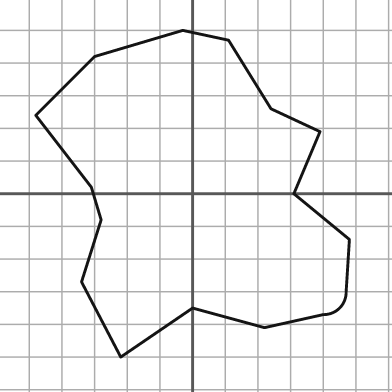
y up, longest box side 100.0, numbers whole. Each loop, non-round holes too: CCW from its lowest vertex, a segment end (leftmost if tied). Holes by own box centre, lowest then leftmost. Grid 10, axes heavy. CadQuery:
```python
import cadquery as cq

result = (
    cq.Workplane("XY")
    .moveTo(-22.0, -50.0)
    .lineTo(0.0, -35.0)
    .lineTo(22.0, -41.0)
    .lineTo(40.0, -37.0)
    .threePointArc((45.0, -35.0), (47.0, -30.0))
    .lineTo(48.0, -14.0)
    .lineTo(31.0, 0.0)
    .lineTo(39.0, 19.0)
    .lineTo(24.0, 26.0)
    .lineTo(11.0, 47.0)
    .lineTo(-3.0, 50.0)
    .lineTo(-30.0, 42.0)
    .lineTo(-48.0, 24.0)
    .lineTo(-31.0, 2.0)
    .lineTo(-28.0, -8.0)
    .lineTo(-34.0, -27.0)
    .close()
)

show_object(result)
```